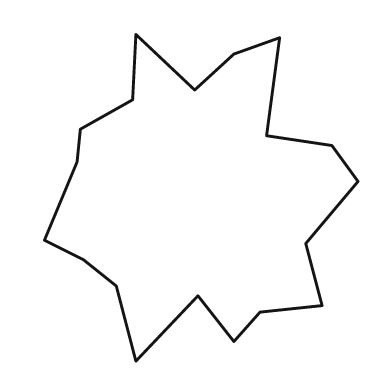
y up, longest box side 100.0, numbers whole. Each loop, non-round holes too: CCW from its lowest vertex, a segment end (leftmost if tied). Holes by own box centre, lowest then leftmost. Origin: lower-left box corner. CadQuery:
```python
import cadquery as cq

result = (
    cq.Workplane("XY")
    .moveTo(28.0, 0.0)
    .lineTo(47.0, 20.0)
    .lineTo(58.0, 6.0)
    .lineTo(66.0, 15.0)
    .lineTo(85.0, 17.0)
    .lineTo(80.0, 36.0)
    .lineTo(96.0, 55.0)
    .lineTo(88.0, 66.0)
    .lineTo(68.0, 69.0)
    .lineTo(72.0, 99.0)
    .lineTo(58.0, 94.0)
    .lineTo(46.0, 83.0)
    .lineTo(28.0, 100.0)
    .lineTo(27.0, 80.0)
    .lineTo(11.0, 71.0)
    .lineTo(10.0, 61.0)
    .lineTo(0.0, 37.0)
    .lineTo(12.0, 31.0)
    .lineTo(22.0, 23.0)
    .close()
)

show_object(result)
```